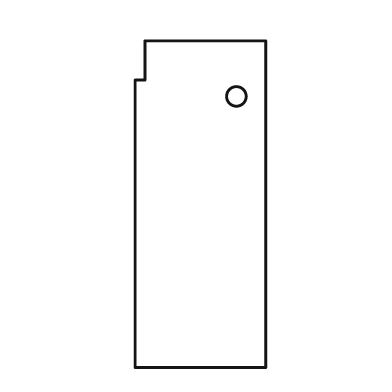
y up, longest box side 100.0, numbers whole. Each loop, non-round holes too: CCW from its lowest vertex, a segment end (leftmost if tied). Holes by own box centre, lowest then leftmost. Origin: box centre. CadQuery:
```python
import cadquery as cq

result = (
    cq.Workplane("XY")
    .moveTo(-20.0, -50.0)
    .lineTo(20.0, -50.0)
    .lineTo(20.0, 50.0)
    .lineTo(-17.0, 50.0)
    .lineTo(-17.0, 38.0)
    .lineTo(-20.0, 38.0)
    .close()
    .moveTo(11.0, 33.0)
    .circle(3.0)
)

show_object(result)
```